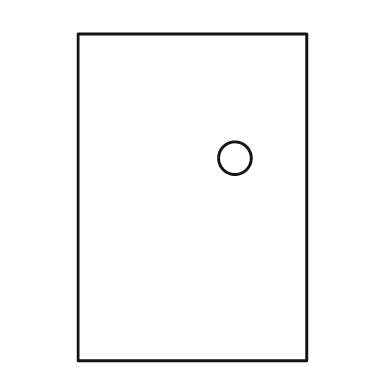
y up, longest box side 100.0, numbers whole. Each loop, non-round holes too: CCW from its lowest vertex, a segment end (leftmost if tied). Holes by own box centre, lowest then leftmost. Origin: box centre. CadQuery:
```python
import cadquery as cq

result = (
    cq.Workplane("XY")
    .moveTo(-35.0, -50.0)
    .lineTo(35.0, -50.0)
    .lineTo(35.0, 50.0)
    .lineTo(-35.0, 50.0)
    .close()
    .moveTo(13.0, 12.0)
    .circle(5.0)
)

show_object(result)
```